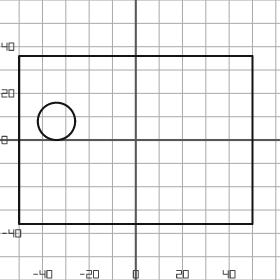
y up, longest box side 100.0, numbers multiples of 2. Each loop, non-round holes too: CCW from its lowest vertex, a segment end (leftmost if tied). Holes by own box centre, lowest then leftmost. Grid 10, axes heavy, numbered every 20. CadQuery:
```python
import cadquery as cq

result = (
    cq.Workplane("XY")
    .moveTo(-50.0, -36.0)
    .lineTo(50.0, -36.0)
    .lineTo(50.0, 36.0)
    .lineTo(-50.0, 36.0)
    .close()
    .moveTo(-34.0, 8.0)
    .circle(8.0)
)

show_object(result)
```